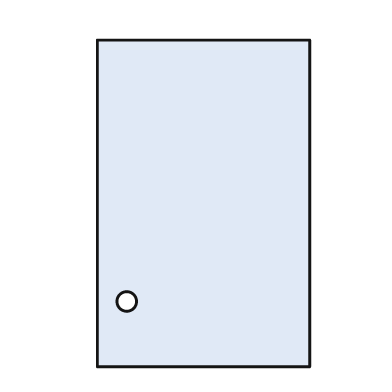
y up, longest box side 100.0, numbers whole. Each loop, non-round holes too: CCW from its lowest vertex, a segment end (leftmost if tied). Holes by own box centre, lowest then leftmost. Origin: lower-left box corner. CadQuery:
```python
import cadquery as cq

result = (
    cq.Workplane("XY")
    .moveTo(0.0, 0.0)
    .lineTo(65.0, 0.0)
    .lineTo(65.0, 100.0)
    .lineTo(0.0, 100.0)
    .close()
    .moveTo(9.0, 20.0)
    .circle(3.0)
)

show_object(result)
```